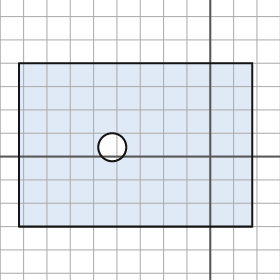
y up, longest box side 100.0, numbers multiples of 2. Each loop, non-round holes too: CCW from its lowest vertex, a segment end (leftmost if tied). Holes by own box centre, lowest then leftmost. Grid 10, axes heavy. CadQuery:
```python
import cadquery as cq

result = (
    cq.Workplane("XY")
    .moveTo(-82.0, -30.0)
    .lineTo(18.0, -30.0)
    .lineTo(18.0, 40.0)
    .lineTo(-82.0, 40.0)
    .close()
    .moveTo(-42.0, 4.0)
    .circle(6.0)
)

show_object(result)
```